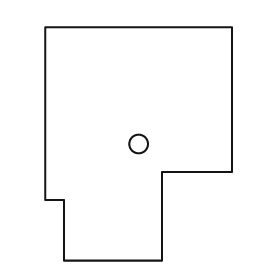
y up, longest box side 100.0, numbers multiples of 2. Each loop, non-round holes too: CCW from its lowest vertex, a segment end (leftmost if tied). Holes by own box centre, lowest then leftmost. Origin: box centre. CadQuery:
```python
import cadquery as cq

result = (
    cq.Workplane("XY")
    .moveTo(-32.0, -50.0)
    .lineTo(10.0, -50.0)
    .lineTo(10.0, -12.0)
    .lineTo(40.0, -12.0)
    .lineTo(40.0, 50.0)
    .lineTo(-40.0, 50.0)
    .lineTo(-40.0, -24.0)
    .lineTo(-32.0, -24.0)
    .close()
    .moveTo(0.0, 0.0)
    .circle(4.0)
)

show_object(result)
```